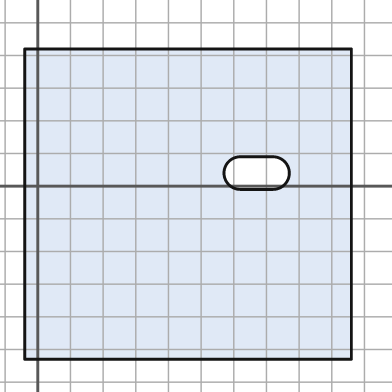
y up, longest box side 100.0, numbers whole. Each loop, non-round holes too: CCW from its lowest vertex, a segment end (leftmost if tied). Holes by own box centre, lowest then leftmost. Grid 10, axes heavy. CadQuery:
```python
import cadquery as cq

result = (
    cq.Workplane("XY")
    .moveTo(-4.0, -53.0)
    .lineTo(96.0, -53.0)
    .lineTo(96.0, 42.0)
    .lineTo(-4.0, 42.0)
    .close()
    .moveTo(62.0, -1.0)
    .lineTo(72.0, -1.0)
    .threePointArc((77.0, 4.0), (72.0, 9.0))
    .lineTo(62.0, 9.0)
    .threePointArc((57.0, 4.0), (62.0, -1.0))
    .close()
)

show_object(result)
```